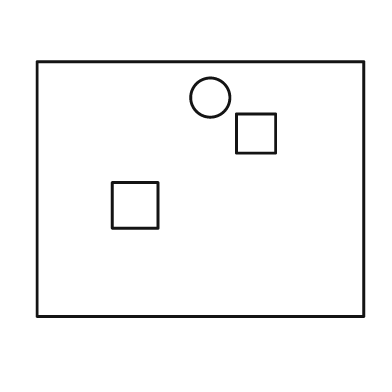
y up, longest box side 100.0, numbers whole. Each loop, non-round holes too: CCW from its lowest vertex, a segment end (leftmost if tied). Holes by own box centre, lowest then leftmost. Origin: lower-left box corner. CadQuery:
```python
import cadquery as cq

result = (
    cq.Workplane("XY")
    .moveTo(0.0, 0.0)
    .lineTo(100.0, 0.0)
    .lineTo(100.0, 78.0)
    .lineTo(0.0, 78.0)
    .close()
    .moveTo(23.0, 27.0)
    .lineTo(37.0, 27.0)
    .lineTo(37.0, 41.0)
    .lineTo(23.0, 41.0)
    .close()
    .moveTo(61.0, 50.0)
    .lineTo(73.0, 50.0)
    .lineTo(73.0, 62.0)
    .lineTo(61.0, 62.0)
    .close()
    .moveTo(53.0, 67.0)
    .circle(6.0)
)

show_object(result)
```